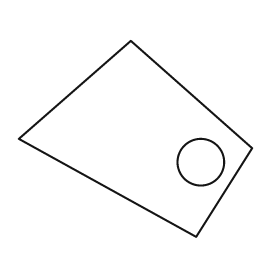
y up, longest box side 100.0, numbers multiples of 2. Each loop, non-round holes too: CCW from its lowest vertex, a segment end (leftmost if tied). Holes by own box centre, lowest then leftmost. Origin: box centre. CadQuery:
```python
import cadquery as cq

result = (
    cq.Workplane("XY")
    .moveTo(26.0, -42.0)
    .lineTo(50.0, -4.0)
    .lineTo(-2.0, 42.0)
    .lineTo(-50.0, 0.0)
    .close()
    .moveTo(28.0, -10.0)
    .circle(10.0)
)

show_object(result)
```